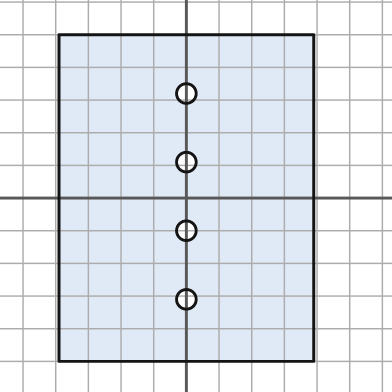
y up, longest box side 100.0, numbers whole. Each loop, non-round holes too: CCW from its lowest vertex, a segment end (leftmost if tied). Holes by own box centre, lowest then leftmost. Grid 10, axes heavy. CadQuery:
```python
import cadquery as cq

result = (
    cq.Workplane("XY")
    .moveTo(-39.0, -50.0)
    .lineTo(39.0, -50.0)
    .lineTo(39.0, 50.0)
    .lineTo(-39.0, 50.0)
    .close()
    .moveTo(0.0, -31.0)
    .circle(3.0)
    .moveTo(0.0, -10.0)
    .circle(3.0)
    .moveTo(0.0, 11.0)
    .circle(3.0)
    .moveTo(0.0, 32.0)
    .circle(3.0)
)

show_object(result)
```